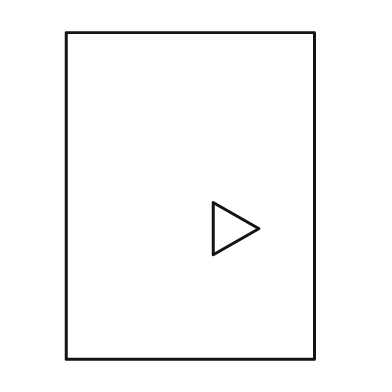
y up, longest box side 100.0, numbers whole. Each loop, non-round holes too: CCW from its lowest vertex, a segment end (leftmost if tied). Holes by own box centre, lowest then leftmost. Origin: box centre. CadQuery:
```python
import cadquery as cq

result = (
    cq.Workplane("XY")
    .moveTo(-38.0, -50.0)
    .lineTo(38.0, -50.0)
    .lineTo(38.0, 50.0)
    .lineTo(-38.0, 50.0)
    .close()
    .moveTo(7.0, -18.0)
    .lineTo(21.0, -10.0)
    .lineTo(7.0, -2.0)
    .close()
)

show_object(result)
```